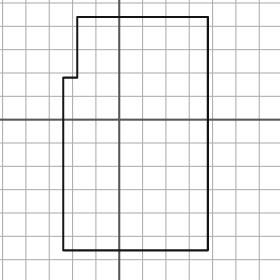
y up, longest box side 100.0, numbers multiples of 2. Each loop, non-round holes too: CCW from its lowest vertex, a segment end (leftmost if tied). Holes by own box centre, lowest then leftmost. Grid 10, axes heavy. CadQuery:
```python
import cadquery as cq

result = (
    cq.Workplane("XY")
    .moveTo(-24.0, -56.0)
    .lineTo(38.0, -56.0)
    .lineTo(38.0, 44.0)
    .lineTo(-18.0, 44.0)
    .lineTo(-18.0, 18.0)
    .lineTo(-24.0, 18.0)
    .close()
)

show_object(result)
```